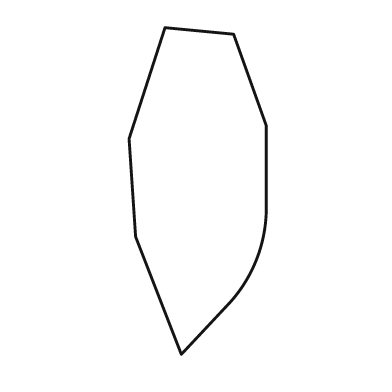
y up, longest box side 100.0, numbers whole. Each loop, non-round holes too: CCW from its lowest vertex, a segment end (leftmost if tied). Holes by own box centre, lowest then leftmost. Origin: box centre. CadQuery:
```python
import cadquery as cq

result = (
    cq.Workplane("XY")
    .moveTo(-5.0, -50.0)
    .lineTo(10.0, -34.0)
    .threePointArc((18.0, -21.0), (21.0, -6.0))
    .lineTo(21.0, 20.0)
    .lineTo(11.0, 48.0)
    .lineTo(-10.0, 50.0)
    .lineTo(-21.0, 16.0)
    .lineTo(-19.0, -14.0)
    .close()
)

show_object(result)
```